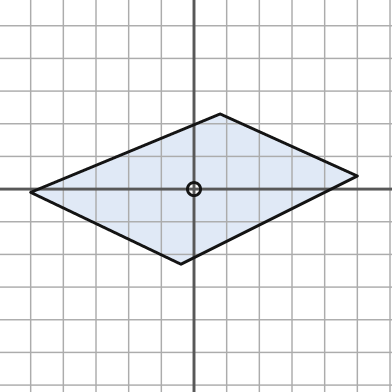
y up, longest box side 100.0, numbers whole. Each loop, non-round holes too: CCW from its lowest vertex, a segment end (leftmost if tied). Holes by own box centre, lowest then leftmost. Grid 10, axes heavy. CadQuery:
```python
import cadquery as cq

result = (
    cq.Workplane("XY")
    .moveTo(-4.0, -23.0)
    .lineTo(50.0, 4.0)
    .lineTo(8.0, 23.0)
    .lineTo(-50.0, -1.0)
    .close()
    .moveTo(0.0, 0.0)
    .circle(2.0)
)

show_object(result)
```